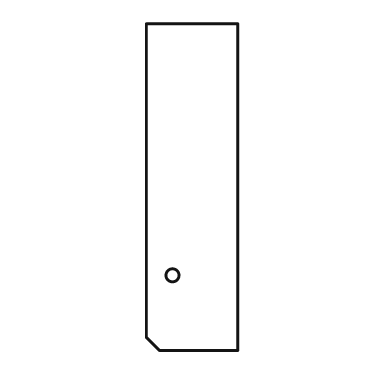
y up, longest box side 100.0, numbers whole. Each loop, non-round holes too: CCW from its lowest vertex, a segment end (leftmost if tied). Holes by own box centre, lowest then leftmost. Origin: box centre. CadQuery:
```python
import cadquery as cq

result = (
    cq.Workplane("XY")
    .moveTo(-10.0, -50.0)
    .lineTo(14.0, -50.0)
    .lineTo(14.0, 50.0)
    .lineTo(-14.0, 50.0)
    .lineTo(-14.0, -46.0)
    .close()
    .moveTo(-6.0, -27.0)
    .circle(2.0)
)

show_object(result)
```